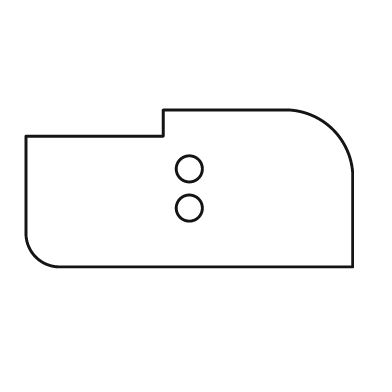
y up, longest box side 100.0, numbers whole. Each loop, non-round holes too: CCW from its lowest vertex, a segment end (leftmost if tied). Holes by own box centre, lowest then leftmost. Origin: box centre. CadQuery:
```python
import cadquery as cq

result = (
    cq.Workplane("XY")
    .moveTo(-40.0, -24.0)
    .lineTo(50.0, -24.0)
    .lineTo(50.0, 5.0)
    .threePointArc((44.0, 18.0), (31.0, 24.0))
    .lineTo(-8.0, 24.0)
    .lineTo(-8.0, 16.0)
    .lineTo(-50.0, 16.0)
    .lineTo(-50.0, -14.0)
    .threePointArc((-47.0, -21.0), (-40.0, -24.0))
    .close()
    .moveTo(0.0, -6.0)
    .circle(4.0)
    .moveTo(0.0, 6.0)
    .circle(4.0)
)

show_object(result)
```